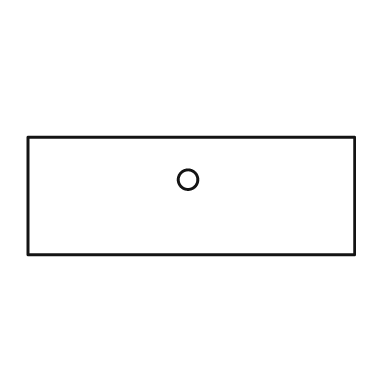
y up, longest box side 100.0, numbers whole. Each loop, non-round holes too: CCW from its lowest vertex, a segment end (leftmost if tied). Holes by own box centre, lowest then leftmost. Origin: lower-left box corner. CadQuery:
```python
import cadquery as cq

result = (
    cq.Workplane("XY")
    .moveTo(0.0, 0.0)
    .lineTo(100.0, 0.0)
    .lineTo(100.0, 36.0)
    .lineTo(0.0, 36.0)
    .close()
    .moveTo(49.0, 23.0)
    .circle(3.0)
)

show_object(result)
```